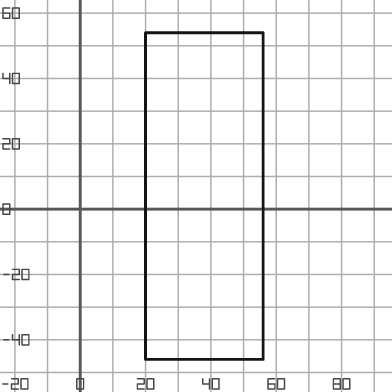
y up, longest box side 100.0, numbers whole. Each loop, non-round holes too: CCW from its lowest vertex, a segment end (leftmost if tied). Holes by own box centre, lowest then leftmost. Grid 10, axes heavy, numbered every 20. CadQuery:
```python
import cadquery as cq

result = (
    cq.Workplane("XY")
    .moveTo(20.0, -46.0)
    .lineTo(56.0, -46.0)
    .lineTo(56.0, 54.0)
    .lineTo(20.0, 54.0)
    .close()
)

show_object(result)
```